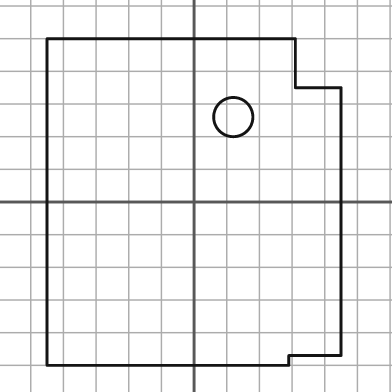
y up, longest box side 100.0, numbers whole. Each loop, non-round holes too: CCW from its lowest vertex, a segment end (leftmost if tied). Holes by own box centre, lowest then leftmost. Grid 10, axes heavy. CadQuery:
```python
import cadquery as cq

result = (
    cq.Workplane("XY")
    .moveTo(-45.0, -50.0)
    .lineTo(29.0, -50.0)
    .lineTo(29.0, -47.0)
    .lineTo(45.0, -47.0)
    .lineTo(45.0, 35.0)
    .lineTo(31.0, 35.0)
    .lineTo(31.0, 50.0)
    .lineTo(-45.0, 50.0)
    .close()
    .moveTo(12.0, 26.0)
    .circle(6.0)
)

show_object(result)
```